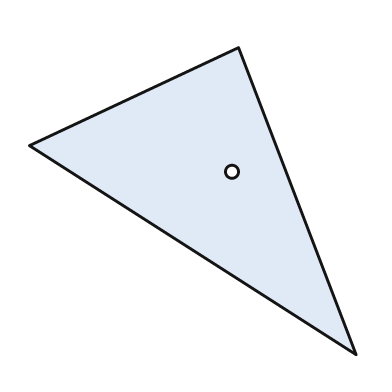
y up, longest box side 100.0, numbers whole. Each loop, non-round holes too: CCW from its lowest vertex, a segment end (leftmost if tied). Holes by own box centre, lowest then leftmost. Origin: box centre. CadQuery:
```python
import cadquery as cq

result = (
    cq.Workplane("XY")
    .moveTo(50.0, -47.0)
    .lineTo(14.0, 47.0)
    .lineTo(-50.0, 17.0)
    .close()
    .moveTo(12.0, 9.0)
    .circle(2.0)
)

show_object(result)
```